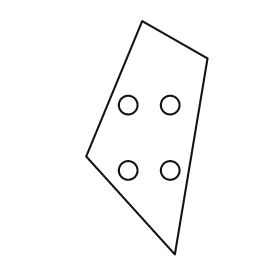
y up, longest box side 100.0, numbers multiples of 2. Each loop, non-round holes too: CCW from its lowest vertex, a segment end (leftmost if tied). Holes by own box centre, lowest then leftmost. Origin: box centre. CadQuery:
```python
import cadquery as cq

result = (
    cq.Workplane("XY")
    .moveTo(12.0, -50.0)
    .lineTo(26.0, 34.0)
    .lineTo(-2.0, 50.0)
    .lineTo(-26.0, -8.0)
    .close()
    .moveTo(-8.0, -14.0)
    .circle(4.0)
    .moveTo(10.0, -14.0)
    .circle(4.0)
    .moveTo(-8.0, 14.0)
    .circle(4.0)
    .moveTo(10.0, 14.0)
    .circle(4.0)
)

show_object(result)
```